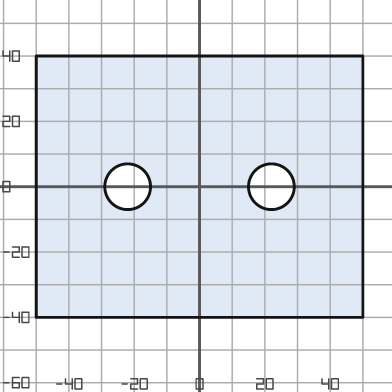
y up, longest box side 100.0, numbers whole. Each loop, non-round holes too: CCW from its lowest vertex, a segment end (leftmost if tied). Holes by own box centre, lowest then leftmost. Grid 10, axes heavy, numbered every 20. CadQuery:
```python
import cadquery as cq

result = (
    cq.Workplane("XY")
    .moveTo(-50.0, -40.0)
    .lineTo(50.0, -40.0)
    .lineTo(50.0, 40.0)
    .lineTo(-50.0, 40.0)
    .close()
    .moveTo(-22.0, 0.0)
    .circle(7.0)
    .moveTo(22.0, 0.0)
    .circle(7.0)
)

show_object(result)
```